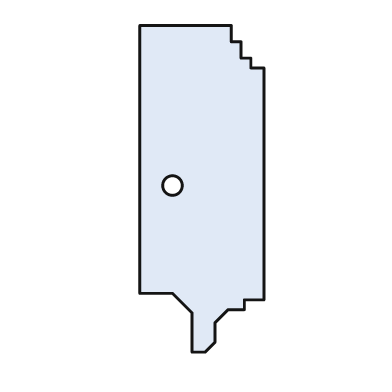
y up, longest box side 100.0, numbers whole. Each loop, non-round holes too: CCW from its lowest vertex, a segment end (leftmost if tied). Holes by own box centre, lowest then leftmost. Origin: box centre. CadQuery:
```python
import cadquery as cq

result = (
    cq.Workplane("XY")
    .moveTo(-3.0, -50.0)
    .lineTo(1.0, -50.0)
    .lineTo(4.0, -47.0)
    .lineTo(4.0, -41.0)
    .lineTo(8.0, -37.0)
    .lineTo(13.0, -37.0)
    .lineTo(13.0, -34.0)
    .lineTo(19.0, -34.0)
    .lineTo(19.0, 37.0)
    .lineTo(15.0, 37.0)
    .lineTo(15.0, 40.0)
    .lineTo(12.0, 40.0)
    .lineTo(12.0, 45.0)
    .lineTo(9.0, 45.0)
    .lineTo(9.0, 50.0)
    .lineTo(-19.0, 50.0)
    .lineTo(-19.0, -32.0)
    .lineTo(-9.0, -32.0)
    .lineTo(-3.0, -38.0)
    .close()
    .moveTo(-9.0, 1.0)
    .circle(3.0)
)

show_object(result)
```